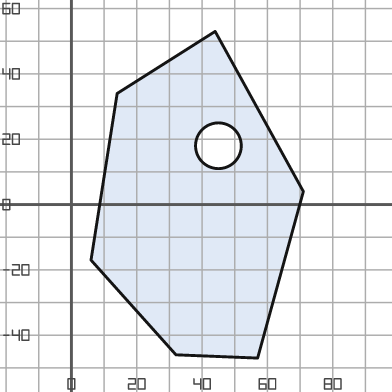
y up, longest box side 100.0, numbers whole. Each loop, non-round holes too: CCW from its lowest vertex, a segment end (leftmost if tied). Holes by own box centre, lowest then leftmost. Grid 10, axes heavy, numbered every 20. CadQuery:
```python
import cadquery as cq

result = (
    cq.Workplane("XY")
    .moveTo(57.0, -47.0)
    .lineTo(71.0, 4.0)
    .lineTo(44.0, 53.0)
    .lineTo(14.0, 34.0)
    .lineTo(6.0, -17.0)
    .lineTo(32.0, -46.0)
    .close()
    .moveTo(45.0, 18.0)
    .circle(7.0)
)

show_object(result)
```